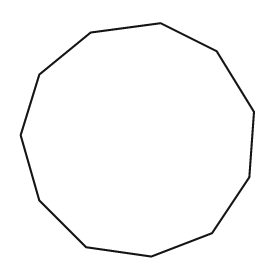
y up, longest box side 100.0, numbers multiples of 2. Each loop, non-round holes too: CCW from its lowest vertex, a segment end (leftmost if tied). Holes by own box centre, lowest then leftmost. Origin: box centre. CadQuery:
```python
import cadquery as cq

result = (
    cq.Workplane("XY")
    .moveTo(6.0, -50.0)
    .lineTo(32.0, -40.0)
    .lineTo(48.0, -16.0)
    .lineTo(50.0, 12.0)
    .lineTo(34.0, 38.0)
    .lineTo(10.0, 50.0)
    .lineTo(-20.0, 46.0)
    .lineTo(-42.0, 28.0)
    .lineTo(-50.0, 2.0)
    .lineTo(-42.0, -26.0)
    .lineTo(-22.0, -46.0)
    .close()
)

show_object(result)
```